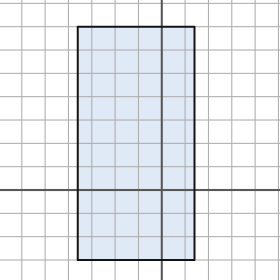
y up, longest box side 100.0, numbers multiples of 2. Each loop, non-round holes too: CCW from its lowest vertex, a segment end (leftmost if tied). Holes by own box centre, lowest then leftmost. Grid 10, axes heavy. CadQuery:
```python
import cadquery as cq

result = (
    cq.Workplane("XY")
    .moveTo(-36.0, -30.0)
    .lineTo(14.0, -30.0)
    .lineTo(14.0, 70.0)
    .lineTo(-36.0, 70.0)
    .close()
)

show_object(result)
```